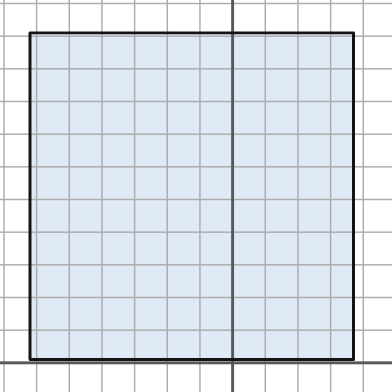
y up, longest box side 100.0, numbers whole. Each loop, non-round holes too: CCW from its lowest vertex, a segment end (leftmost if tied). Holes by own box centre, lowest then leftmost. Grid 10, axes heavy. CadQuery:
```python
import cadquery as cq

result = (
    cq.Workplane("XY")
    .moveTo(-62.0, 1.0)
    .lineTo(37.0, 1.0)
    .lineTo(37.0, 101.0)
    .lineTo(-62.0, 101.0)
    .close()
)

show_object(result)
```